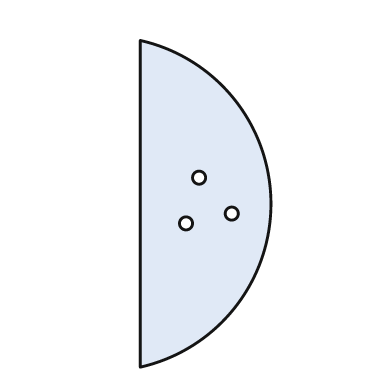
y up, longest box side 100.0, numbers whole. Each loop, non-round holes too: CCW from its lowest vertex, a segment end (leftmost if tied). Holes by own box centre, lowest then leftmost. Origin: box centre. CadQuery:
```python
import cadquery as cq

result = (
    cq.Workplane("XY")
    .moveTo(-20.0, -50.0)
    .threePointArc((20.0, 0.0), (-20.0, 50.0))
    .close()
    .moveTo(-6.0, -6.0)
    .circle(2.0)
    .moveTo(8.0, -3.0)
    .circle(2.0)
    .moveTo(-2.0, 8.0)
    .circle(2.0)
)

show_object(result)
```